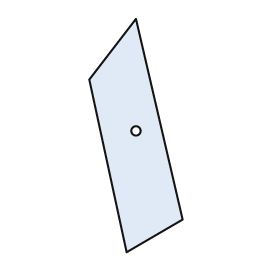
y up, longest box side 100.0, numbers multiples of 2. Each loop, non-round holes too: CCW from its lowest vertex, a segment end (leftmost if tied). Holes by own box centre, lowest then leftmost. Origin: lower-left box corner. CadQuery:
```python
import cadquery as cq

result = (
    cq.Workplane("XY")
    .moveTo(16.0, 0.0)
    .lineTo(40.0, 14.0)
    .lineTo(20.0, 100.0)
    .lineTo(0.0, 74.0)
    .close()
    .moveTo(20.0, 52.0)
    .circle(2.0)
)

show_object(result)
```